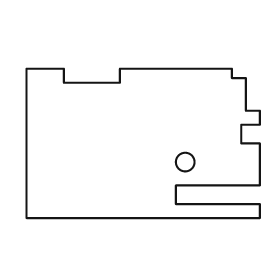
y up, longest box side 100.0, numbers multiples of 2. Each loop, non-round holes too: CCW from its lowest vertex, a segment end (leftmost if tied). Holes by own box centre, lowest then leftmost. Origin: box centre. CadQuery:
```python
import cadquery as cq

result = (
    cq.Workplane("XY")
    .moveTo(-50.0, -32.0)
    .lineTo(50.0, -32.0)
    .lineTo(50.0, -26.0)
    .lineTo(14.0, -26.0)
    .lineTo(14.0, -18.0)
    .lineTo(50.0, -18.0)
    .lineTo(50.0, 0.0)
    .lineTo(42.0, 0.0)
    .lineTo(42.0, 8.0)
    .lineTo(50.0, 8.0)
    .lineTo(50.0, 14.0)
    .lineTo(44.0, 14.0)
    .lineTo(44.0, 28.0)
    .lineTo(38.0, 28.0)
    .lineTo(38.0, 32.0)
    .lineTo(-10.0, 32.0)
    .lineTo(-10.0, 26.0)
    .lineTo(-34.0, 26.0)
    .lineTo(-34.0, 32.0)
    .lineTo(-50.0, 32.0)
    .close()
    .moveTo(18.0, -8.0)
    .circle(4.0)
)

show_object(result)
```